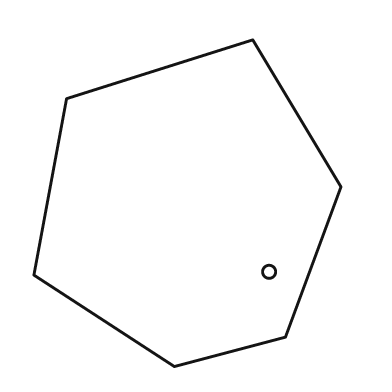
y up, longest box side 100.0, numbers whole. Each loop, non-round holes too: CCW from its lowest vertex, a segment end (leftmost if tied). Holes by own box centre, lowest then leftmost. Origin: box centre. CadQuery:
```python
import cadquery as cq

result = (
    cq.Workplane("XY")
    .moveTo(-4.0, -50.0)
    .lineTo(30.0, -41.0)
    .lineTo(47.0, 5.0)
    .lineTo(20.0, 50.0)
    .lineTo(-37.0, 32.0)
    .lineTo(-47.0, -22.0)
    .close()
    .moveTo(25.0, -21.0)
    .circle(2.0)
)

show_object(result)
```